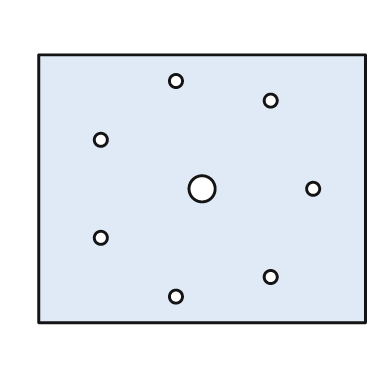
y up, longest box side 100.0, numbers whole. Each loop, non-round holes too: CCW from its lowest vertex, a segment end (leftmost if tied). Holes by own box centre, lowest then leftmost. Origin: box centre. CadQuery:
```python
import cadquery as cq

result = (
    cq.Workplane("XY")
    .moveTo(-50.0, -41.0)
    .lineTo(50.0, -41.0)
    .lineTo(50.0, 41.0)
    .lineTo(-50.0, 41.0)
    .close()
    .moveTo(-8.0, -33.0)
    .circle(2.0)
    .moveTo(21.0, -27.0)
    .circle(2.0)
    .moveTo(-31.0, -15.0)
    .circle(2.0)
    .moveTo(0.0, 0.0)
    .circle(4.0)
    .moveTo(34.0, 0.0)
    .circle(2.0)
    .moveTo(-31.0, 15.0)
    .circle(2.0)
    .moveTo(21.0, 27.0)
    .circle(2.0)
    .moveTo(-8.0, 33.0)
    .circle(2.0)
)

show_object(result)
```